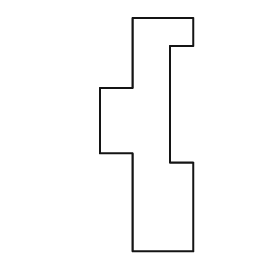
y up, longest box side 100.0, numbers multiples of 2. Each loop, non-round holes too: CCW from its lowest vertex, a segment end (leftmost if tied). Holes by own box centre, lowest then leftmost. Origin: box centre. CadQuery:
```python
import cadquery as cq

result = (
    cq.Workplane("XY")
    .moveTo(-6.0, -50.0)
    .lineTo(20.0, -50.0)
    .lineTo(20.0, -12.0)
    .lineTo(10.0, -12.0)
    .lineTo(10.0, 38.0)
    .lineTo(20.0, 38.0)
    .lineTo(20.0, 50.0)
    .lineTo(-6.0, 50.0)
    .lineTo(-6.0, 20.0)
    .lineTo(-20.0, 20.0)
    .lineTo(-20.0, -8.0)
    .lineTo(-6.0, -8.0)
    .close()
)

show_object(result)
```